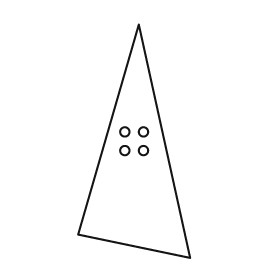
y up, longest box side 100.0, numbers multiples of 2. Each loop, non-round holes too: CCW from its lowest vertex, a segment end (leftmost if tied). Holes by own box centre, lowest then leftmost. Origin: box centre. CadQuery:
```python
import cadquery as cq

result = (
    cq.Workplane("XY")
    .moveTo(24.0, -50.0)
    .lineTo(2.0, 50.0)
    .lineTo(-24.0, -40.0)
    .close()
    .moveTo(-4.0, -4.0)
    .circle(2.0)
    .moveTo(4.0, -4.0)
    .circle(2.0)
    .moveTo(-4.0, 4.0)
    .circle(2.0)
    .moveTo(4.0, 4.0)
    .circle(2.0)
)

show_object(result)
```